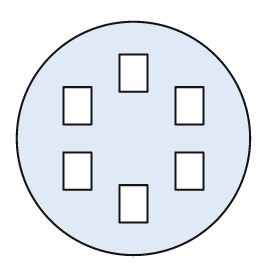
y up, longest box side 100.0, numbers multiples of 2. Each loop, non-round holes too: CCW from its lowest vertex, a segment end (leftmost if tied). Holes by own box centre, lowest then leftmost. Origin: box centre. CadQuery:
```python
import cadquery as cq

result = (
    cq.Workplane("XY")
    .moveTo(0.0, 0.0)
    .circle(50.0)
    .moveTo(-6.0, -36.0)
    .lineTo(6.0, -36.0)
    .lineTo(6.0, -20.0)
    .lineTo(-6.0, -20.0)
    .close()
    .moveTo(-30.0, -22.0)
    .lineTo(-18.0, -22.0)
    .lineTo(-18.0, -6.0)
    .lineTo(-30.0, -6.0)
    .close()
    .moveTo(18.0, -22.0)
    .lineTo(30.0, -22.0)
    .lineTo(30.0, -6.0)
    .lineTo(18.0, -6.0)
    .close()
    .moveTo(-30.0, 6.0)
    .lineTo(-18.0, 6.0)
    .lineTo(-18.0, 22.0)
    .lineTo(-30.0, 22.0)
    .close()
    .moveTo(18.0, 6.0)
    .lineTo(30.0, 6.0)
    .lineTo(30.0, 22.0)
    .lineTo(18.0, 22.0)
    .close()
    .moveTo(-6.0, 20.0)
    .lineTo(6.0, 20.0)
    .lineTo(6.0, 36.0)
    .lineTo(-6.0, 36.0)
    .close()
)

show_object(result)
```